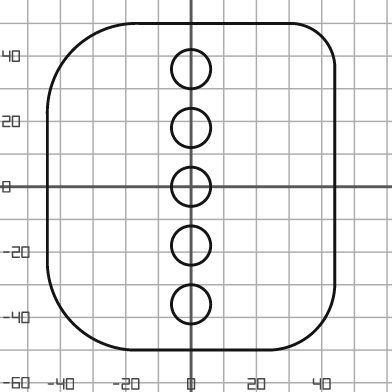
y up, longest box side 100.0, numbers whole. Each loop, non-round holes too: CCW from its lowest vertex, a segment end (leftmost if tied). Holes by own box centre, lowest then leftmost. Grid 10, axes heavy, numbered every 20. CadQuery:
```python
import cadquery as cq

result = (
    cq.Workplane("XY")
    .moveTo(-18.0, -50.0)
    .lineTo(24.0, -50.0)
    .threePointArc((38.0, -44.0), (44.0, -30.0))
    .lineTo(44.0, 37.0)
    .threePointArc((40.0, 46.0), (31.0, 50.0))
    .lineTo(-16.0, 50.0)
    .threePointArc((-36.0, 42.0), (-44.0, 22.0))
    .lineTo(-44.0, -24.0)
    .threePointArc((-36.0, -42.0), (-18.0, -50.0))
    .close()
    .moveTo(0.0, -36.0)
    .circle(6.0)
    .moveTo(0.0, -18.0)
    .circle(6.0)
    .moveTo(0.0, 0.0)
    .circle(6.0)
    .moveTo(0.0, 18.0)
    .circle(6.0)
    .moveTo(0.0, 36.0)
    .circle(6.0)
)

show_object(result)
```